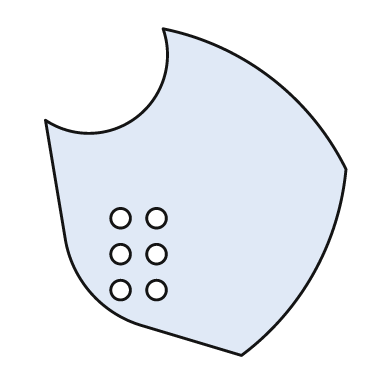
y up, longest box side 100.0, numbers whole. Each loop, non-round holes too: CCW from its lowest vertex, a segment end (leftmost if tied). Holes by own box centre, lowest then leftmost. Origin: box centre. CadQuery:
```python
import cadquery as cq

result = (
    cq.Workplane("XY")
    .moveTo(14.0, -50.0)
    .threePointArc((36.0, -25.0), (46.0, 7.0))
    .threePointArc((23.0, 35.0), (-10.0, 50.0))
    .threePointArc((-18.0, 23.0), (-46.0, 22.0))
    .lineTo(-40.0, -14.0)
    .threePointArc((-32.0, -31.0), (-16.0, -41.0))
    .close()
    .moveTo(-23.0, -30.0)
    .circle(3.0)
    .moveTo(-12.0, -30.0)
    .circle(3.0)
    .moveTo(-23.0, -19.0)
    .circle(3.0)
    .moveTo(-12.0, -19.0)
    .circle(3.0)
    .moveTo(-23.0, -8.0)
    .circle(3.0)
    .moveTo(-12.0, -8.0)
    .circle(3.0)
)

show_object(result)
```